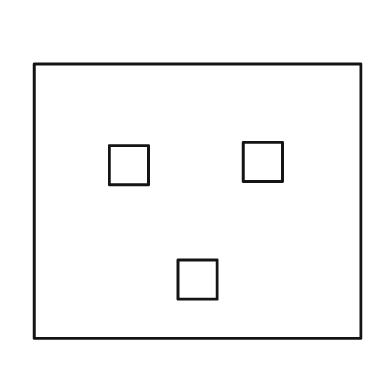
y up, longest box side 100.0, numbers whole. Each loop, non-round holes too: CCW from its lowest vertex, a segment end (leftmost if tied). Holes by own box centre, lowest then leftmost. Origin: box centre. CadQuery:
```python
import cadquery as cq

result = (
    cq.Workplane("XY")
    .moveTo(-50.0, -42.0)
    .lineTo(50.0, -42.0)
    .lineTo(50.0, 42.0)
    .lineTo(-50.0, 42.0)
    .close()
    .moveTo(-6.0, -30.0)
    .lineTo(6.0, -30.0)
    .lineTo(6.0, -18.0)
    .lineTo(-6.0, -18.0)
    .close()
    .moveTo(-27.0, 5.0)
    .lineTo(-15.0, 5.0)
    .lineTo(-15.0, 17.0)
    .lineTo(-27.0, 17.0)
    .close()
    .moveTo(14.0, 6.0)
    .lineTo(26.0, 6.0)
    .lineTo(26.0, 18.0)
    .lineTo(14.0, 18.0)
    .close()
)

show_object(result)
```